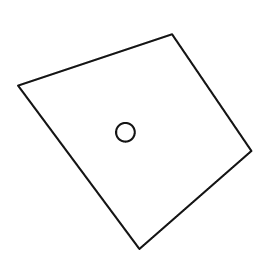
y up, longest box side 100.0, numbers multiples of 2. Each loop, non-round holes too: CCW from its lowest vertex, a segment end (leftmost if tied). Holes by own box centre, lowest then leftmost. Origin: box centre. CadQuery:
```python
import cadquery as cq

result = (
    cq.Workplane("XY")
    .moveTo(2.0, -46.0)
    .lineTo(50.0, -4.0)
    .lineTo(16.0, 46.0)
    .lineTo(-50.0, 24.0)
    .close()
    .moveTo(-4.0, 4.0)
    .circle(4.0)
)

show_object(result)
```